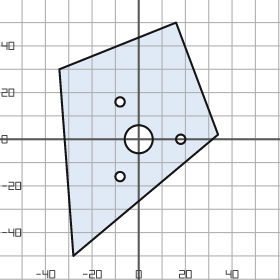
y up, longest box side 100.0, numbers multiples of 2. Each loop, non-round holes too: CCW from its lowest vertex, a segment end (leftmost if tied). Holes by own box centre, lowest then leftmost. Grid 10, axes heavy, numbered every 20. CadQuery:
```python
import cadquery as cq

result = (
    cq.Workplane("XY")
    .moveTo(-28.0, -50.0)
    .lineTo(34.0, 2.0)
    .lineTo(16.0, 50.0)
    .lineTo(-34.0, 30.0)
    .close()
    .moveTo(-8.0, -16.0)
    .circle(2.0)
    .moveTo(0.0, 0.0)
    .circle(6.0)
    .moveTo(18.0, 0.0)
    .circle(2.0)
    .moveTo(-8.0, 16.0)
    .circle(2.0)
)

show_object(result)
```